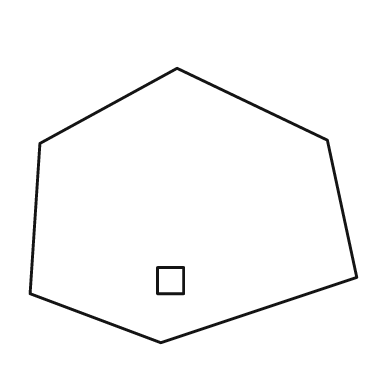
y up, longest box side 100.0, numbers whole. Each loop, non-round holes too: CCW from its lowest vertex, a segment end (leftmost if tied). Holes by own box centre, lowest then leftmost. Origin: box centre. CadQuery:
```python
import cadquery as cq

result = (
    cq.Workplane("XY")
    .moveTo(-10.0, -42.0)
    .lineTo(50.0, -22.0)
    .lineTo(41.0, 20.0)
    .lineTo(-5.0, 42.0)
    .lineTo(-47.0, 19.0)
    .lineTo(-50.0, -27.0)
    .close()
    .moveTo(-11.0, -27.0)
    .lineTo(-3.0, -27.0)
    .lineTo(-3.0, -19.0)
    .lineTo(-11.0, -19.0)
    .close()
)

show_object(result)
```